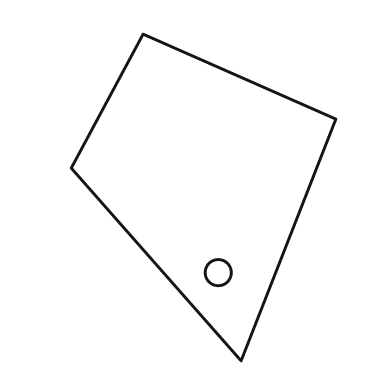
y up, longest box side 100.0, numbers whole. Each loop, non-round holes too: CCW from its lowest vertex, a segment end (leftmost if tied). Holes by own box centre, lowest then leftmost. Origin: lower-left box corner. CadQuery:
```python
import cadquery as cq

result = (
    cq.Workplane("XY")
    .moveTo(52.0, 0.0)
    .lineTo(81.0, 74.0)
    .lineTo(22.0, 100.0)
    .lineTo(0.0, 59.0)
    .close()
    .moveTo(45.0, 27.0)
    .circle(4.0)
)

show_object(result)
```